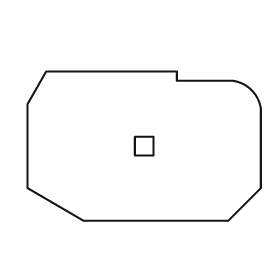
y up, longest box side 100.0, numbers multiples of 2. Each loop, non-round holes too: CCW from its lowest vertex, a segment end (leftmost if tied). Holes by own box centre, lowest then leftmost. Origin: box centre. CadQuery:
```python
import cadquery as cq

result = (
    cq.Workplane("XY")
    .moveTo(-26.0, -32.0)
    .lineTo(36.0, -32.0)
    .lineTo(50.0, -18.0)
    .lineTo(50.0, 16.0)
    .threePointArc((46.0, 24.0), (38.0, 28.0))
    .lineTo(14.0, 28.0)
    .lineTo(14.0, 32.0)
    .lineTo(-42.0, 32.0)
    .lineTo(-50.0, 18.0)
    .lineTo(-50.0, -18.0)
    .close()
    .moveTo(-4.0, -4.0)
    .lineTo(4.0, -4.0)
    .lineTo(4.0, 4.0)
    .lineTo(-4.0, 4.0)
    .close()
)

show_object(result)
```